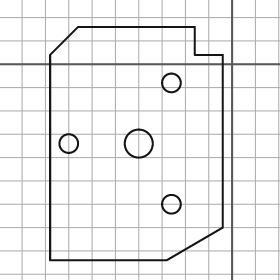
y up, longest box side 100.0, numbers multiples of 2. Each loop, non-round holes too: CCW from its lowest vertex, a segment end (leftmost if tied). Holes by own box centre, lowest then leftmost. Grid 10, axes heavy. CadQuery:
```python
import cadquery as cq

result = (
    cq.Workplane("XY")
    .moveTo(-78.0, -84.0)
    .lineTo(-28.0, -84.0)
    .lineTo(-4.0, -70.0)
    .lineTo(-4.0, 4.0)
    .lineTo(-16.0, 4.0)
    .lineTo(-16.0, 16.0)
    .lineTo(-66.0, 16.0)
    .lineTo(-78.0, 4.0)
    .close()
    .moveTo(-26.0, -60.0)
    .circle(4.0)
    .moveTo(-70.0, -34.0)
    .circle(4.0)
    .moveTo(-40.0, -34.0)
    .circle(6.0)
    .moveTo(-26.0, -8.0)
    .circle(4.0)
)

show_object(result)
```